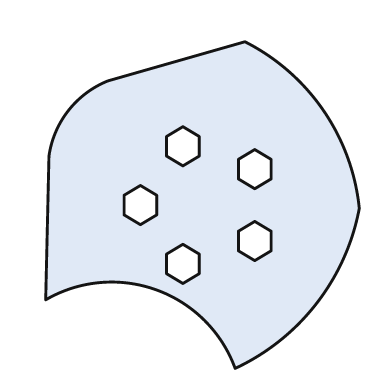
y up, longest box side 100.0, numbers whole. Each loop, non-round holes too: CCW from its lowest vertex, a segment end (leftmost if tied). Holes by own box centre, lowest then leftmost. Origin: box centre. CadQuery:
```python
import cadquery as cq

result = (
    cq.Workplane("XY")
    .moveTo(10.0, -50.0)
    .threePointArc((35.0, -30.0), (48.0, -1.0))
    .threePointArc((37.0, 29.0), (13.0, 50.0))
    .lineTo(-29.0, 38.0)
    .threePointArc((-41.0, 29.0), (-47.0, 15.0))
    .lineTo(-48.0, -29.0)
    .threePointArc((-14.0, -26.0), (10.0, -50.0))
    .close()
    .moveTo(-6.0, -24.0)
    .lineTo(-1.0, -21.0)
    .lineTo(-1.0, -15.0)
    .lineTo(-6.0, -12.0)
    .lineTo(-11.0, -15.0)
    .lineTo(-11.0, -21.0)
    .close()
    .moveTo(16.0, -17.0)
    .lineTo(21.0, -14.0)
    .lineTo(21.0, -8.0)
    .lineTo(16.0, -5.0)
    .lineTo(11.0, -8.0)
    .lineTo(11.0, -14.0)
    .close()
    .moveTo(-19.0, -6.0)
    .lineTo(-14.0, -3.0)
    .lineTo(-14.0, 3.0)
    .lineTo(-19.0, 6.0)
    .lineTo(-24.0, 3.0)
    .lineTo(-24.0, -3.0)
    .close()
    .moveTo(16.0, 5.0)
    .lineTo(21.0, 8.0)
    .lineTo(21.0, 14.0)
    .lineTo(16.0, 17.0)
    .lineTo(11.0, 14.0)
    .lineTo(11.0, 8.0)
    .close()
    .moveTo(-6.0, 12.0)
    .lineTo(-1.0, 15.0)
    .lineTo(-1.0, 21.0)
    .lineTo(-6.0, 24.0)
    .lineTo(-11.0, 21.0)
    .lineTo(-11.0, 15.0)
    .close()
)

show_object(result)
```